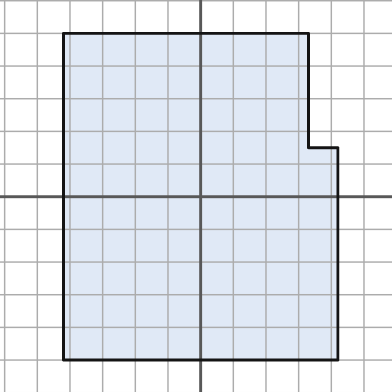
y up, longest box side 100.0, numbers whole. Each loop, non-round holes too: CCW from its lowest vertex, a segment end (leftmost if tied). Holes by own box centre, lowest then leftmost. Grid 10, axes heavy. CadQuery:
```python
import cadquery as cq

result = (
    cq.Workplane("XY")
    .moveTo(-42.0, -50.0)
    .lineTo(42.0, -50.0)
    .lineTo(42.0, 15.0)
    .lineTo(33.0, 15.0)
    .lineTo(33.0, 50.0)
    .lineTo(-42.0, 50.0)
    .close()
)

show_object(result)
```